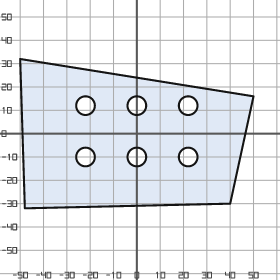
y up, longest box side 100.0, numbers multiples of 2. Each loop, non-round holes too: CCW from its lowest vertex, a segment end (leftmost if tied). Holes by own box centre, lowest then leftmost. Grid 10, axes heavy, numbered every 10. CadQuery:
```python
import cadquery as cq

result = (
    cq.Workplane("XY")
    .moveTo(-48.0, -32.0)
    .lineTo(40.0, -30.0)
    .lineTo(50.0, 16.0)
    .lineTo(-50.0, 32.0)
    .close()
    .moveTo(-22.0, -10.0)
    .circle(4.0)
    .moveTo(0.0, -10.0)
    .circle(4.0)
    .moveTo(22.0, -10.0)
    .circle(4.0)
    .moveTo(-22.0, 12.0)
    .circle(4.0)
    .moveTo(0.0, 12.0)
    .circle(4.0)
    .moveTo(22.0, 12.0)
    .circle(4.0)
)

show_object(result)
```